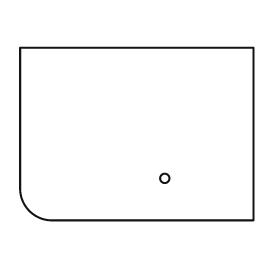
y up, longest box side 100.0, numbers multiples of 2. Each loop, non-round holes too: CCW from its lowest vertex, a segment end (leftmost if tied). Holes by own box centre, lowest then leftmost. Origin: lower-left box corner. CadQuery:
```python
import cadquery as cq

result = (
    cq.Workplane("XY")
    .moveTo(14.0, 0.0)
    .lineTo(100.0, 0.0)
    .lineTo(100.0, 74.0)
    .lineTo(0.0, 74.0)
    .lineTo(0.0, 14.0)
    .threePointArc((4.0, 4.0), (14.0, 0.0))
    .close()
    .moveTo(62.0, 18.0)
    .circle(2.0)
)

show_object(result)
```